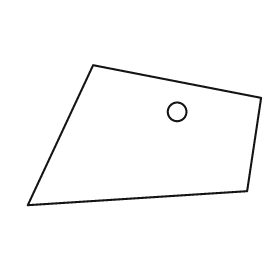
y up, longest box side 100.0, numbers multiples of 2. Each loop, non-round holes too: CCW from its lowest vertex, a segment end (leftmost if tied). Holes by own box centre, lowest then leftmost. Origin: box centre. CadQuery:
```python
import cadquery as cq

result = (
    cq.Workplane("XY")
    .moveTo(-50.0, -30.0)
    .lineTo(44.0, -24.0)
    .lineTo(50.0, 16.0)
    .lineTo(-22.0, 30.0)
    .close()
    .moveTo(14.0, 10.0)
    .circle(4.0)
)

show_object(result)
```